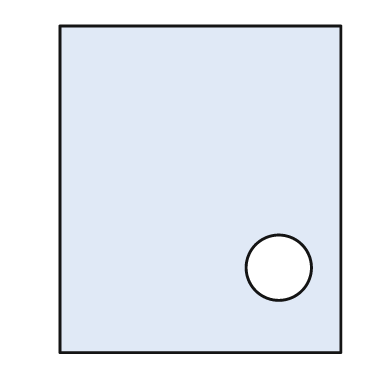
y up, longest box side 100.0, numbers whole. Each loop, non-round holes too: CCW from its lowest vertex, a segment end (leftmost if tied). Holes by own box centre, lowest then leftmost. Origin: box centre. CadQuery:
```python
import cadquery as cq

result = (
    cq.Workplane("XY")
    .moveTo(-43.0, -50.0)
    .lineTo(43.0, -50.0)
    .lineTo(43.0, 50.0)
    .lineTo(-43.0, 50.0)
    .close()
    .moveTo(24.0, -24.0)
    .circle(10.0)
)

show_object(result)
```